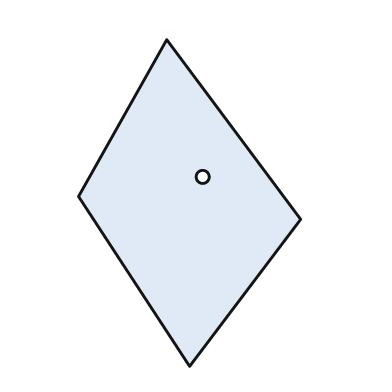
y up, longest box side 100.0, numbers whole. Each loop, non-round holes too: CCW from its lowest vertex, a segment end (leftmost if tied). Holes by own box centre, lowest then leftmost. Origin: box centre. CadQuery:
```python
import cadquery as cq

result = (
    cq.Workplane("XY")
    .moveTo(0.0, -50.0)
    .lineTo(34.0, -5.0)
    .lineTo(-7.0, 50.0)
    .lineTo(-34.0, 2.0)
    .close()
    .moveTo(4.0, 8.0)
    .circle(2.0)
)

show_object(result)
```